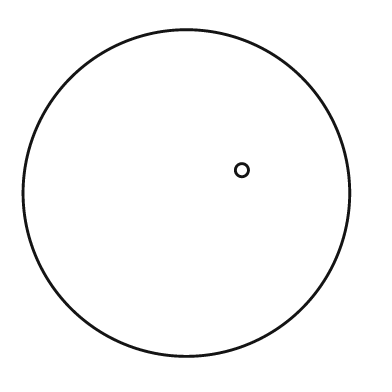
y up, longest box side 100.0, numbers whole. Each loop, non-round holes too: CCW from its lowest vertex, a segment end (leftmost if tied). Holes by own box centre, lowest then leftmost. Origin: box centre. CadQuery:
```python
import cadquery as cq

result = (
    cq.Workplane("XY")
    .moveTo(0.0, 0.0)
    .circle(50.0)
    .moveTo(17.0, 7.0)
    .circle(2.0)
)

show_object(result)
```